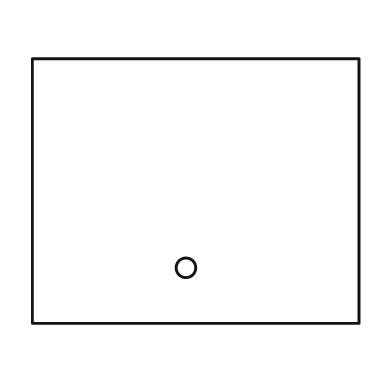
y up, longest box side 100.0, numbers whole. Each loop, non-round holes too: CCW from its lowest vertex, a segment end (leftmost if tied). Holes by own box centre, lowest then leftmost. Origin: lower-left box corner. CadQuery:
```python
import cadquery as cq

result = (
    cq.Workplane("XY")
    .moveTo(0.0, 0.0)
    .lineTo(100.0, 0.0)
    .lineTo(100.0, 81.0)
    .lineTo(0.0, 81.0)
    .close()
    .moveTo(47.0, 17.0)
    .circle(3.0)
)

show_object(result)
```